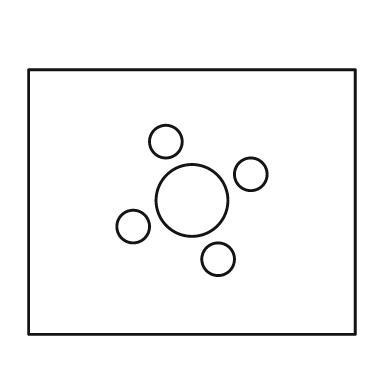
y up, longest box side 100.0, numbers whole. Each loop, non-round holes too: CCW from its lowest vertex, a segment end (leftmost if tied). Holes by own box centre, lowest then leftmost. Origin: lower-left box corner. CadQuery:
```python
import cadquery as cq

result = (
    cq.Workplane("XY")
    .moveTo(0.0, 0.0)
    .lineTo(100.0, 0.0)
    .lineTo(100.0, 81.0)
    .lineTo(0.0, 81.0)
    .close()
    .moveTo(58.0, 23.0)
    .circle(5.0)
    .moveTo(32.0, 33.0)
    .circle(5.0)
    .moveTo(50.0, 41.0)
    .circle(11.0)
    .moveTo(68.0, 49.0)
    .circle(5.0)
    .moveTo(42.0, 59.0)
    .circle(5.0)
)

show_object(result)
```